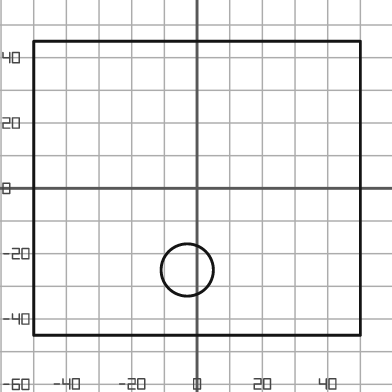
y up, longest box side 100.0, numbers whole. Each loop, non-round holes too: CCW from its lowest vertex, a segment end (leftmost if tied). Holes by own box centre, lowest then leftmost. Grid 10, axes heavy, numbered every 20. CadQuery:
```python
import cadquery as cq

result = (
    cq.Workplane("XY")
    .moveTo(-50.0, -45.0)
    .lineTo(50.0, -45.0)
    .lineTo(50.0, 45.0)
    .lineTo(-50.0, 45.0)
    .close()
    .moveTo(-3.0, -25.0)
    .circle(8.0)
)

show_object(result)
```